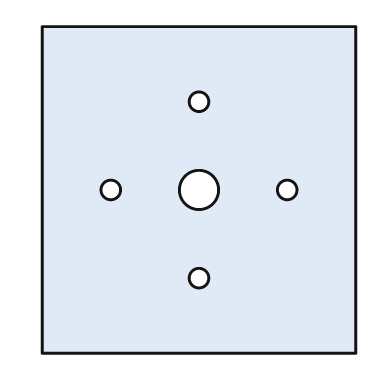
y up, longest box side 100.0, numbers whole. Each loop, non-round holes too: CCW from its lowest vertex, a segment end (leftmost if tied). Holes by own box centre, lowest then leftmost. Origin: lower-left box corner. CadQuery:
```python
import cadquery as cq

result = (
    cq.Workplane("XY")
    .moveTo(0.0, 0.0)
    .lineTo(96.0, 0.0)
    .lineTo(96.0, 100.0)
    .lineTo(0.0, 100.0)
    .close()
    .moveTo(48.0, 23.0)
    .circle(3.0)
    .moveTo(21.0, 50.0)
    .circle(3.0)
    .moveTo(48.0, 50.0)
    .circle(6.0)
    .moveTo(75.0, 50.0)
    .circle(3.0)
    .moveTo(48.0, 77.0)
    .circle(3.0)
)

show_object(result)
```